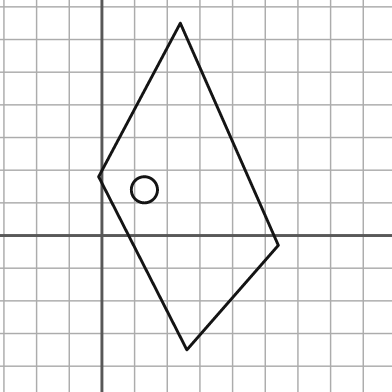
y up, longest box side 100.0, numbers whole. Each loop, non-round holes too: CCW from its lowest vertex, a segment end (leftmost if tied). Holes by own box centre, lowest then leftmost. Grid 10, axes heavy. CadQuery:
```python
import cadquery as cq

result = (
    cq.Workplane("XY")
    .moveTo(26.0, -35.0)
    .lineTo(54.0, -3.0)
    .lineTo(24.0, 65.0)
    .lineTo(-1.0, 18.0)
    .close()
    .moveTo(13.0, 14.0)
    .circle(4.0)
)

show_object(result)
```